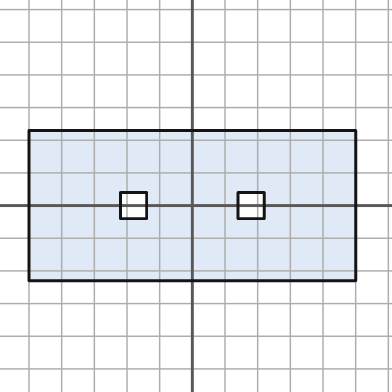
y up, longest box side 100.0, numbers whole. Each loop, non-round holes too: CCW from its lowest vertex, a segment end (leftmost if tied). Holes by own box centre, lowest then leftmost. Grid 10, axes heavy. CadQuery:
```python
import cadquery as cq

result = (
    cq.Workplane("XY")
    .moveTo(-50.0, -23.0)
    .lineTo(50.0, -23.0)
    .lineTo(50.0, 23.0)
    .lineTo(-50.0, 23.0)
    .close()
    .moveTo(-22.0, -4.0)
    .lineTo(-14.0, -4.0)
    .lineTo(-14.0, 4.0)
    .lineTo(-22.0, 4.0)
    .close()
    .moveTo(14.0, -4.0)
    .lineTo(22.0, -4.0)
    .lineTo(22.0, 4.0)
    .lineTo(14.0, 4.0)
    .close()
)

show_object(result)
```